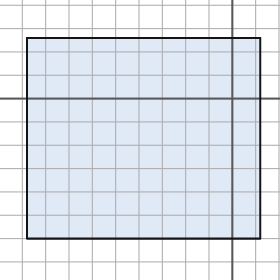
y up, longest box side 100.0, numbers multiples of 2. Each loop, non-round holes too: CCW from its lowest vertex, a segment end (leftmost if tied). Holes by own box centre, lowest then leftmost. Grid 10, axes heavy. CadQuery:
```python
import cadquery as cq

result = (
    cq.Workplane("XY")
    .moveTo(-88.0, -60.0)
    .lineTo(12.0, -60.0)
    .lineTo(12.0, 26.0)
    .lineTo(-88.0, 26.0)
    .close()
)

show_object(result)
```